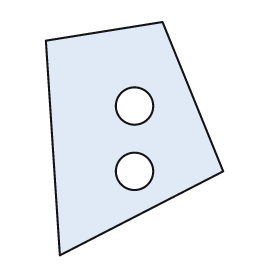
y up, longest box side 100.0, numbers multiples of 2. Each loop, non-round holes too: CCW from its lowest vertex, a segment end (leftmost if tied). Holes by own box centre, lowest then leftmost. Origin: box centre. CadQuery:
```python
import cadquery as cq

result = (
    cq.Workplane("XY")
    .moveTo(-32.0, -50.0)
    .lineTo(38.0, -14.0)
    .lineTo(12.0, 50.0)
    .lineTo(-38.0, 42.0)
    .close()
    .moveTo(0.0, -14.0)
    .circle(8.0)
    .moveTo(0.0, 14.0)
    .circle(8.0)
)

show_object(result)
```